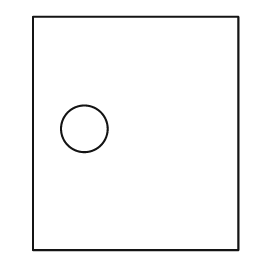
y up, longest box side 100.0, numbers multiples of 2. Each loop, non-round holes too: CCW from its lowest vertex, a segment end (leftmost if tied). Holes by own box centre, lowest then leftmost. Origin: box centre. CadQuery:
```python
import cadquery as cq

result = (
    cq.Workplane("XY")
    .moveTo(-44.0, -50.0)
    .lineTo(44.0, -50.0)
    .lineTo(44.0, 50.0)
    .lineTo(-44.0, 50.0)
    .close()
    .moveTo(-22.0, 2.0)
    .circle(10.0)
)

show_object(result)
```